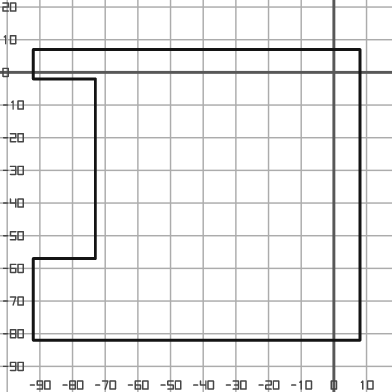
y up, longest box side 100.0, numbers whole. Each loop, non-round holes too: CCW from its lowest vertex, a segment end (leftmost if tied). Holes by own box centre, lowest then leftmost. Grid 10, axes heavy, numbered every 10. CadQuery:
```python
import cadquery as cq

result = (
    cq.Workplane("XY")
    .moveTo(-92.0, -82.0)
    .lineTo(8.0, -82.0)
    .lineTo(8.0, 7.0)
    .lineTo(-92.0, 7.0)
    .lineTo(-92.0, -2.0)
    .lineTo(-73.0, -2.0)
    .lineTo(-73.0, -57.0)
    .lineTo(-92.0, -57.0)
    .close()
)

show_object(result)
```